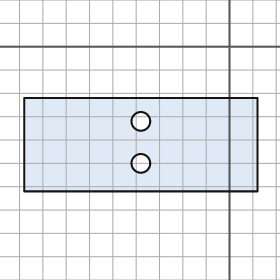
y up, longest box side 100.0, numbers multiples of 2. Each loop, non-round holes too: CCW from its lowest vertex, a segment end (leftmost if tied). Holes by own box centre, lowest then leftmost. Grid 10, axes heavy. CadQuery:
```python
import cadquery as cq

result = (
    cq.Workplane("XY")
    .moveTo(-88.0, -62.0)
    .lineTo(12.0, -62.0)
    .lineTo(12.0, -22.0)
    .lineTo(-88.0, -22.0)
    .close()
    .moveTo(-38.0, -50.0)
    .circle(4.0)
    .moveTo(-38.0, -32.0)
    .circle(4.0)
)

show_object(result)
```